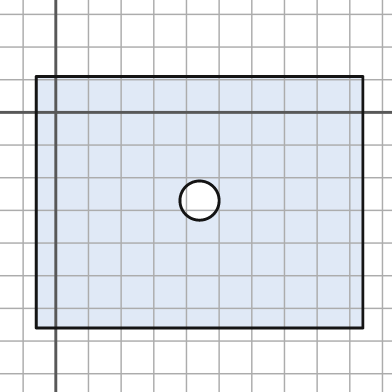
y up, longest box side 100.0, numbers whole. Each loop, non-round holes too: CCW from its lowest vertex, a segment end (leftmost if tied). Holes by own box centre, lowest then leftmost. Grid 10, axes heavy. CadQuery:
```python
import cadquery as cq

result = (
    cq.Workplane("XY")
    .moveTo(-6.0, -66.0)
    .lineTo(94.0, -66.0)
    .lineTo(94.0, 11.0)
    .lineTo(-6.0, 11.0)
    .close()
    .moveTo(44.0, -27.0)
    .circle(6.0)
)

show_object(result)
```